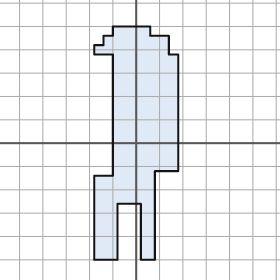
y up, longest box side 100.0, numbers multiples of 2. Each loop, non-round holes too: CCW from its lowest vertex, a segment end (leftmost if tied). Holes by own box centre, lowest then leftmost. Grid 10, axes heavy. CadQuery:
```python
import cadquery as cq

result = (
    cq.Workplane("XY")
    .moveTo(-18.0, -50.0)
    .lineTo(-8.0, -50.0)
    .lineTo(-8.0, -26.0)
    .lineTo(2.0, -26.0)
    .lineTo(2.0, -50.0)
    .lineTo(8.0, -50.0)
    .lineTo(8.0, -12.0)
    .lineTo(18.0, -12.0)
    .lineTo(18.0, 38.0)
    .lineTo(14.0, 38.0)
    .lineTo(14.0, 46.0)
    .lineTo(6.0, 46.0)
    .lineTo(6.0, 50.0)
    .lineTo(-10.0, 50.0)
    .lineTo(-10.0, 46.0)
    .lineTo(-14.0, 46.0)
    .lineTo(-14.0, 42.0)
    .lineTo(-18.0, 42.0)
    .lineTo(-18.0, 38.0)
    .lineTo(-10.0, 38.0)
    .lineTo(-10.0, -14.0)
    .lineTo(-18.0, -14.0)
    .close()
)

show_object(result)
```